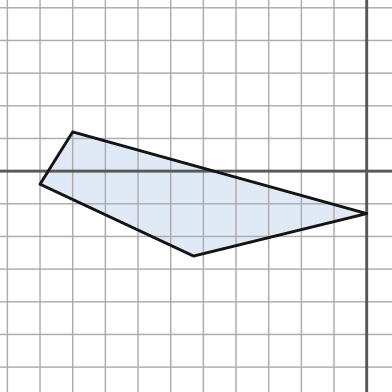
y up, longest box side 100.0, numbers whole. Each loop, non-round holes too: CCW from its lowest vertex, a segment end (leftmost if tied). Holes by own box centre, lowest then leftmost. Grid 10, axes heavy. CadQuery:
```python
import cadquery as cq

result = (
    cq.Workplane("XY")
    .moveTo(-53.0, -26.0)
    .lineTo(0.0, -13.0)
    .lineTo(-90.0, 12.0)
    .lineTo(-100.0, -4.0)
    .close()
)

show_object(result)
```